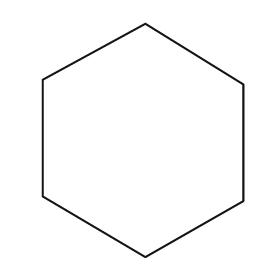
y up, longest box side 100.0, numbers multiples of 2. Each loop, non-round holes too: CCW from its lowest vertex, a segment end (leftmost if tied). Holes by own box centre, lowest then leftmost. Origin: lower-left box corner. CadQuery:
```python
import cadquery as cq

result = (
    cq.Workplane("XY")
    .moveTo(44.0, 0.0)
    .lineTo(86.0, 24.0)
    .lineTo(86.0, 74.0)
    .lineTo(44.0, 100.0)
    .lineTo(0.0, 76.0)
    .lineTo(0.0, 26.0)
    .close()
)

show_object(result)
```